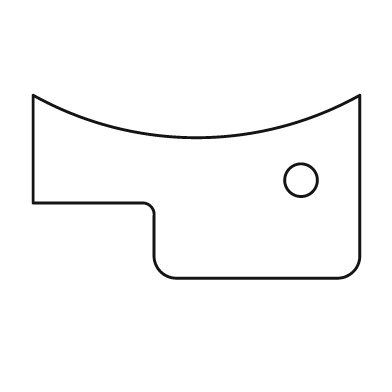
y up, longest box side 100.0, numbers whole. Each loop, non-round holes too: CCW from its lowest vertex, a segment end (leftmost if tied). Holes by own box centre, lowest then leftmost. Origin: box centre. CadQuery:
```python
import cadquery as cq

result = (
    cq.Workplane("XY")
    .moveTo(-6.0, -28.0)
    .lineTo(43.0, -28.0)
    .threePointArc((48.0, -26.0), (50.0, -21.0))
    .lineTo(50.0, 28.0)
    .threePointArc((0.0, 15.0), (-50.0, 28.0))
    .lineTo(-50.0, -5.0)
    .lineTo(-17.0, -5.0)
    .threePointArc((-14.0, -6.0), (-13.0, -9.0))
    .lineTo(-13.0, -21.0)
    .threePointArc((-11.0, -26.0), (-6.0, -28.0))
    .close()
    .moveTo(32.0, 2.0)
    .circle(5.0)
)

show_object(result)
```